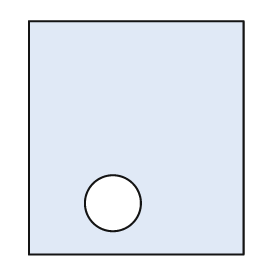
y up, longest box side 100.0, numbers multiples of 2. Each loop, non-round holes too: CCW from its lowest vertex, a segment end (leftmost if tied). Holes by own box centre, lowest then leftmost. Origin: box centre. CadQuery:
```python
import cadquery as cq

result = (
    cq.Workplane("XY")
    .moveTo(-46.0, -50.0)
    .lineTo(46.0, -50.0)
    .lineTo(46.0, 50.0)
    .lineTo(-46.0, 50.0)
    .close()
    .moveTo(-10.0, -28.0)
    .circle(12.0)
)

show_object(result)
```